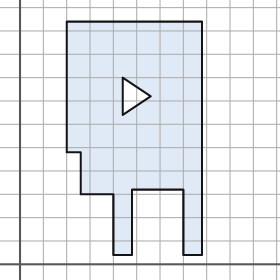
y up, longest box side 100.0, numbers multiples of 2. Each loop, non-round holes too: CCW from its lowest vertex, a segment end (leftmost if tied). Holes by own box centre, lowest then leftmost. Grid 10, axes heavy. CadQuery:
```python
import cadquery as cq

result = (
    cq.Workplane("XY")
    .moveTo(40.0, 4.0)
    .lineTo(48.0, 4.0)
    .lineTo(48.0, 32.0)
    .lineTo(70.0, 32.0)
    .lineTo(70.0, 4.0)
    .lineTo(78.0, 4.0)
    .lineTo(78.0, 104.0)
    .lineTo(20.0, 104.0)
    .lineTo(20.0, 48.0)
    .lineTo(26.0, 48.0)
    .lineTo(26.0, 30.0)
    .lineTo(40.0, 30.0)
    .close()
    .moveTo(44.0, 64.0)
    .lineTo(56.0, 72.0)
    .lineTo(44.0, 80.0)
    .close()
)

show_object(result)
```